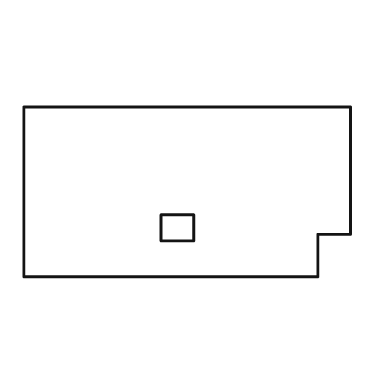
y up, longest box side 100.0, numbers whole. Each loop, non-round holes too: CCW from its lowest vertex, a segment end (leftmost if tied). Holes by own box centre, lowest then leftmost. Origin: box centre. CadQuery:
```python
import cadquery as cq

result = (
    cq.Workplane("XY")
    .moveTo(-50.0, -26.0)
    .lineTo(40.0, -26.0)
    .lineTo(40.0, -13.0)
    .lineTo(50.0, -13.0)
    .lineTo(50.0, 26.0)
    .lineTo(-50.0, 26.0)
    .close()
    .moveTo(-8.0, -15.0)
    .lineTo(2.0, -15.0)
    .lineTo(2.0, -7.0)
    .lineTo(-8.0, -7.0)
    .close()
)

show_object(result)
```